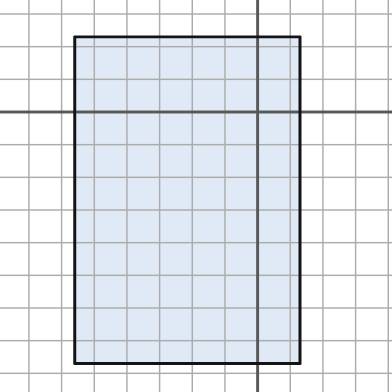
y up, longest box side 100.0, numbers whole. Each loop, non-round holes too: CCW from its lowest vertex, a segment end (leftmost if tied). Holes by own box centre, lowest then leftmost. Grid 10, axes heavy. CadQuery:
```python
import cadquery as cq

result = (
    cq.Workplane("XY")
    .moveTo(-56.0, -77.0)
    .lineTo(13.0, -77.0)
    .lineTo(13.0, 23.0)
    .lineTo(-56.0, 23.0)
    .close()
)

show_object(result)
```